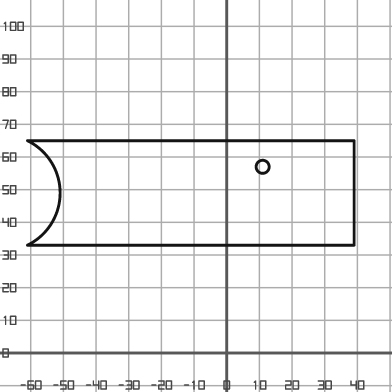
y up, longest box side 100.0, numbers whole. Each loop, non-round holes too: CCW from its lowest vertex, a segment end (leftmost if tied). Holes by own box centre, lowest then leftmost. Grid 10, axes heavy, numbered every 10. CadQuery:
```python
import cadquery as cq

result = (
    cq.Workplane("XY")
    .moveTo(-61.0, 33.0)
    .lineTo(39.0, 33.0)
    .lineTo(39.0, 65.0)
    .lineTo(-61.0, 65.0)
    .threePointArc((-51.0, 49.0), (-61.0, 33.0))
    .close()
    .moveTo(11.0, 57.0)
    .circle(2.0)
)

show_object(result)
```